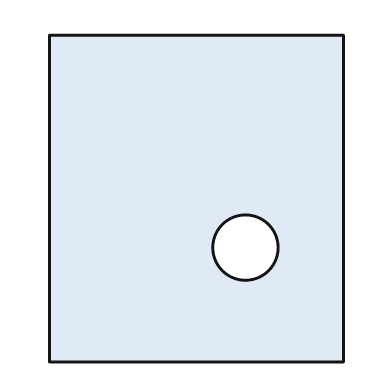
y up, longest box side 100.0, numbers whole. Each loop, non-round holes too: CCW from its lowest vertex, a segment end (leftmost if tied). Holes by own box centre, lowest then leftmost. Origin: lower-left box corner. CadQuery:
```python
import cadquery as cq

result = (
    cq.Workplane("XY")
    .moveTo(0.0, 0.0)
    .lineTo(90.0, 0.0)
    .lineTo(90.0, 100.0)
    .lineTo(0.0, 100.0)
    .close()
    .moveTo(60.0, 35.0)
    .circle(10.0)
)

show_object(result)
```